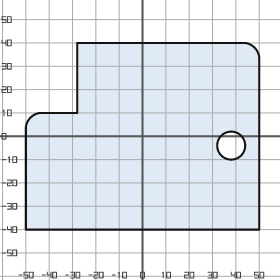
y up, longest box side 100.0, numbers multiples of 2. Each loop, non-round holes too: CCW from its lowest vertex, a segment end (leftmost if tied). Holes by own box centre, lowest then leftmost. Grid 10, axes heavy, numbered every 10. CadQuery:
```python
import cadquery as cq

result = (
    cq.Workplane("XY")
    .moveTo(-50.0, -40.0)
    .lineTo(50.0, -40.0)
    .lineTo(50.0, 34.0)
    .threePointArc((48.0, 38.0), (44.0, 40.0))
    .lineTo(-28.0, 40.0)
    .lineTo(-28.0, 10.0)
    .lineTo(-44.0, 10.0)
    .threePointArc((-48.0, 8.0), (-50.0, 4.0))
    .close()
    .moveTo(38.0, -4.0)
    .circle(6.0)
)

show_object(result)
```